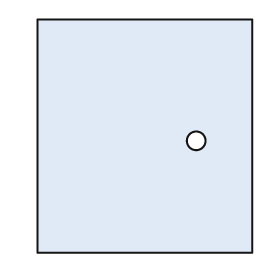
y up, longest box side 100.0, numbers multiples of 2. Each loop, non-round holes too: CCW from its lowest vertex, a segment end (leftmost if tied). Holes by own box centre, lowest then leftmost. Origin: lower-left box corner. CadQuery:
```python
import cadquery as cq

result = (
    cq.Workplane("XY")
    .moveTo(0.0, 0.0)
    .lineTo(92.0, 0.0)
    .lineTo(92.0, 100.0)
    .lineTo(0.0, 100.0)
    .close()
    .moveTo(68.0, 48.0)
    .circle(4.0)
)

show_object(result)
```